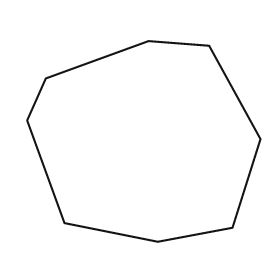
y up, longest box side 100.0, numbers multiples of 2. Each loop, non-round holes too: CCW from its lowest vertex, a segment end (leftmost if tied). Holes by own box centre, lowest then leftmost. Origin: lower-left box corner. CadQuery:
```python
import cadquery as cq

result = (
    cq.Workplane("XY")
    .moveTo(56.0, 0.0)
    .lineTo(88.0, 6.0)
    .lineTo(100.0, 44.0)
    .lineTo(78.0, 84.0)
    .lineTo(52.0, 86.0)
    .lineTo(8.0, 70.0)
    .lineTo(0.0, 52.0)
    .lineTo(16.0, 8.0)
    .close()
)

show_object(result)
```